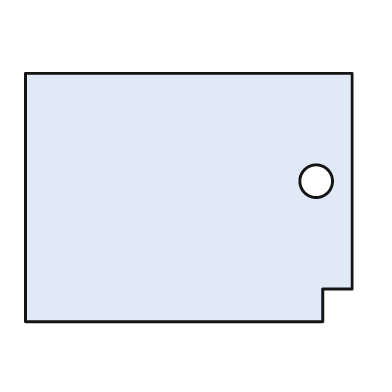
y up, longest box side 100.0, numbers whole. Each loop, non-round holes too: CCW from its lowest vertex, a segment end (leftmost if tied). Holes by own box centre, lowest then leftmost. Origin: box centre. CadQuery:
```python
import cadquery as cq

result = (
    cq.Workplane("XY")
    .moveTo(-50.0, -38.0)
    .lineTo(41.0, -38.0)
    .lineTo(41.0, -28.0)
    .lineTo(50.0, -28.0)
    .lineTo(50.0, 38.0)
    .lineTo(-50.0, 38.0)
    .close()
    .moveTo(39.0, 5.0)
    .circle(5.0)
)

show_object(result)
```